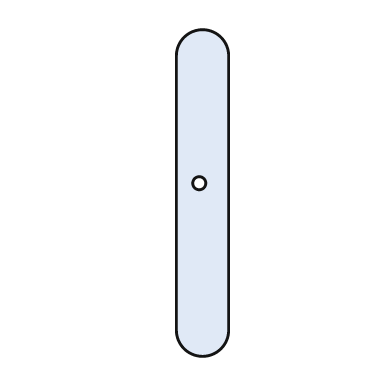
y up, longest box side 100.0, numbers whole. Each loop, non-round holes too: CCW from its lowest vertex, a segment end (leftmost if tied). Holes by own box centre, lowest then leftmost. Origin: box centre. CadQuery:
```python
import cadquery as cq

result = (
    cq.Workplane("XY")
    .moveTo(-8.0, -42.0)
    .threePointArc((0.0, -50.0), (8.0, -42.0))
    .lineTo(8.0, 42.0)
    .threePointArc((0.0, 50.0), (-8.0, 42.0))
    .close()
    .moveTo(-1.0, 3.0)
    .circle(2.0)
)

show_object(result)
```